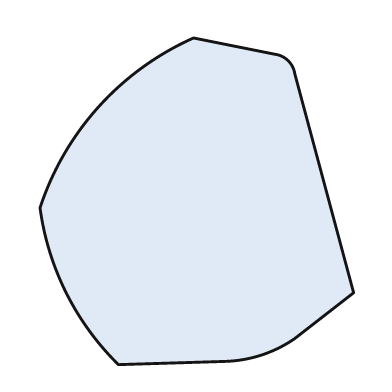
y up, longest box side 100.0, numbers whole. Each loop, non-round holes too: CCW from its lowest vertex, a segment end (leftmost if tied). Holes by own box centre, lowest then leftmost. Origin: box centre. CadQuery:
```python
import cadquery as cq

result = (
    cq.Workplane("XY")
    .moveTo(-24.0, -50.0)
    .lineTo(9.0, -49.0)
    .threePointArc((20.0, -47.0), (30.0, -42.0))
    .lineTo(48.0, -28.0)
    .lineTo(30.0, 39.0)
    .threePointArc((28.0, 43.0), (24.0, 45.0))
    .lineTo(-1.0, 50.0)
    .threePointArc((-30.0, 29.0), (-48.0, -2.0))
    .threePointArc((-40.0, -28.0), (-24.0, -50.0))
    .close()
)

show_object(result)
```